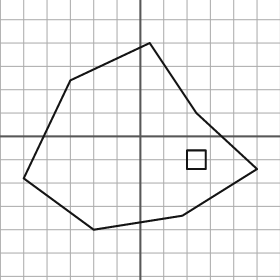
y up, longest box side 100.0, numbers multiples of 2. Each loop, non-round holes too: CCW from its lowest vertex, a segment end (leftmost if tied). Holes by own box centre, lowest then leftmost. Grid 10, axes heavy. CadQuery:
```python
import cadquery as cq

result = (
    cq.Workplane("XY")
    .moveTo(-20.0, -40.0)
    .lineTo(18.0, -34.0)
    .lineTo(50.0, -14.0)
    .lineTo(24.0, 10.0)
    .lineTo(4.0, 40.0)
    .lineTo(-30.0, 24.0)
    .lineTo(-50.0, -18.0)
    .close()
    .moveTo(20.0, -14.0)
    .lineTo(28.0, -14.0)
    .lineTo(28.0, -6.0)
    .lineTo(20.0, -6.0)
    .close()
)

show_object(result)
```